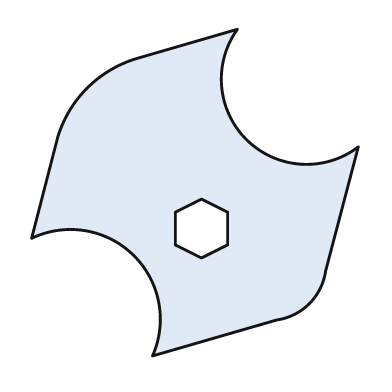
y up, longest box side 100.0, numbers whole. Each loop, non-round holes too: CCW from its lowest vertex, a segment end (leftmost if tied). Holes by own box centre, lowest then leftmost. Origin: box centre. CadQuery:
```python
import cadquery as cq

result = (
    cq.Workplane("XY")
    .moveTo(-13.0, -50.0)
    .lineTo(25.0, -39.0)
    .threePointArc((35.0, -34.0), (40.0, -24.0))
    .lineTo(50.0, 14.0)
    .threePointArc((16.0, 16.0), (13.0, 50.0))
    .lineTo(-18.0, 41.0)
    .threePointArc((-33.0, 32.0), (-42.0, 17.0))
    .lineTo(-50.0, -14.0)
    .threePointArc((-19.0, -19.0), (-13.0, -50.0))
    .close()
    .moveTo(2.0, -20.0)
    .lineTo(10.0, -16.0)
    .lineTo(10.0, -6.0)
    .lineTo(2.0, -2.0)
    .lineTo(-6.0, -6.0)
    .lineTo(-6.0, -16.0)
    .close()
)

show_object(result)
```